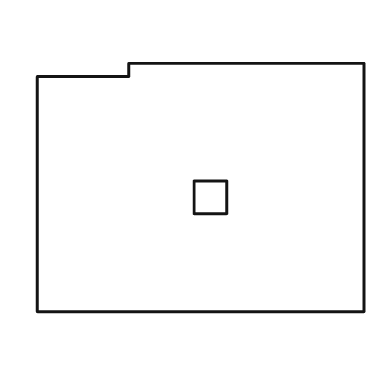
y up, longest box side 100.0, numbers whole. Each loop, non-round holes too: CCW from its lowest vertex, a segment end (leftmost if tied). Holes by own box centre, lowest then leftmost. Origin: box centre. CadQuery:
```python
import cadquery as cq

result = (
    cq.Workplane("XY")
    .moveTo(-50.0, -38.0)
    .lineTo(50.0, -38.0)
    .lineTo(50.0, 38.0)
    .lineTo(-22.0, 38.0)
    .lineTo(-22.0, 34.0)
    .lineTo(-50.0, 34.0)
    .close()
    .moveTo(-2.0, -8.0)
    .lineTo(8.0, -8.0)
    .lineTo(8.0, 2.0)
    .lineTo(-2.0, 2.0)
    .close()
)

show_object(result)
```